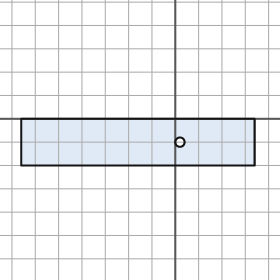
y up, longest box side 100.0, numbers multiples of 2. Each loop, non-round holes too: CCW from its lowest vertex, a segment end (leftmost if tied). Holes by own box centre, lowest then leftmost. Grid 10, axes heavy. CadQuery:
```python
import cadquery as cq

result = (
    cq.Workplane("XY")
    .moveTo(-66.0, -20.0)
    .lineTo(34.0, -20.0)
    .lineTo(34.0, 0.0)
    .lineTo(-66.0, 0.0)
    .close()
    .moveTo(2.0, -10.0)
    .circle(2.0)
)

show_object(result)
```